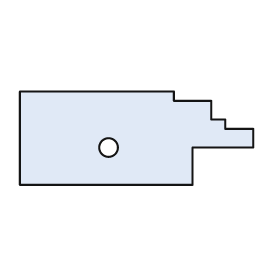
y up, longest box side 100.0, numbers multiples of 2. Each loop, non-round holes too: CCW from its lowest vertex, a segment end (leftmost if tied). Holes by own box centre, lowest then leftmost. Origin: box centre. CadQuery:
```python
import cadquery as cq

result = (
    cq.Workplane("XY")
    .moveTo(-50.0, -20.0)
    .lineTo(24.0, -20.0)
    .lineTo(24.0, -4.0)
    .lineTo(50.0, -4.0)
    .lineTo(50.0, 4.0)
    .lineTo(38.0, 4.0)
    .lineTo(38.0, 8.0)
    .lineTo(32.0, 8.0)
    .lineTo(32.0, 16.0)
    .lineTo(16.0, 16.0)
    .lineTo(16.0, 20.0)
    .lineTo(-50.0, 20.0)
    .close()
    .moveTo(-12.0, -4.0)
    .circle(4.0)
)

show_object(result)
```